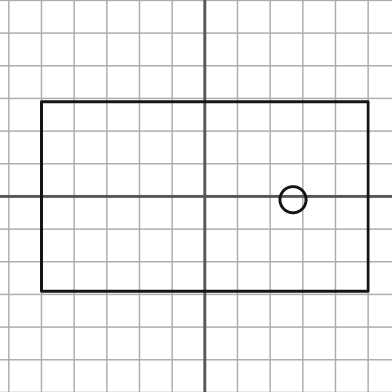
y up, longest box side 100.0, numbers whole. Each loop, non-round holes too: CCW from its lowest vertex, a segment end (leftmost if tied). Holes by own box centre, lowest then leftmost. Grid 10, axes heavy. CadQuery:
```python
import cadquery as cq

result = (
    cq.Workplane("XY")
    .moveTo(-50.0, -29.0)
    .lineTo(50.0, -29.0)
    .lineTo(50.0, 29.0)
    .lineTo(-50.0, 29.0)
    .close()
    .moveTo(27.0, -1.0)
    .circle(4.0)
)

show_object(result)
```